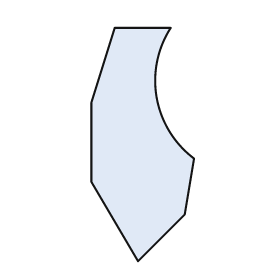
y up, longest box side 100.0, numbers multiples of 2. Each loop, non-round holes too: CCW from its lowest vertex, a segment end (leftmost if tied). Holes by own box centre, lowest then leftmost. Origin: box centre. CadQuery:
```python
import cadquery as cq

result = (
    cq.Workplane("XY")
    .moveTo(-2.0, -50.0)
    .lineTo(18.0, -30.0)
    .lineTo(22.0, -6.0)
    .threePointArc((6.0, 20.0), (12.0, 50.0))
    .lineTo(-12.0, 50.0)
    .lineTo(-22.0, 18.0)
    .lineTo(-22.0, -16.0)
    .close()
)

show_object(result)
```